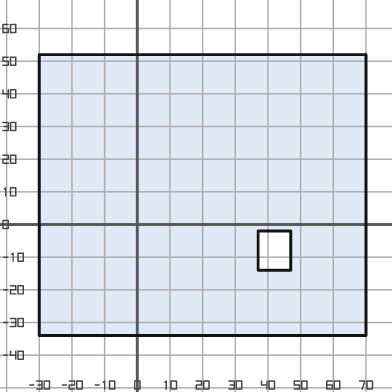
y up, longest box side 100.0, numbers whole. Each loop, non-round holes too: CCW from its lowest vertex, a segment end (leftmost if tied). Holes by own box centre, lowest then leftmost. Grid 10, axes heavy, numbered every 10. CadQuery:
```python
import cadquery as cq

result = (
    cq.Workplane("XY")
    .moveTo(-30.0, -34.0)
    .lineTo(70.0, -34.0)
    .lineTo(70.0, 52.0)
    .lineTo(-30.0, 52.0)
    .close()
    .moveTo(37.0, -14.0)
    .lineTo(47.0, -14.0)
    .lineTo(47.0, -2.0)
    .lineTo(37.0, -2.0)
    .close()
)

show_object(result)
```